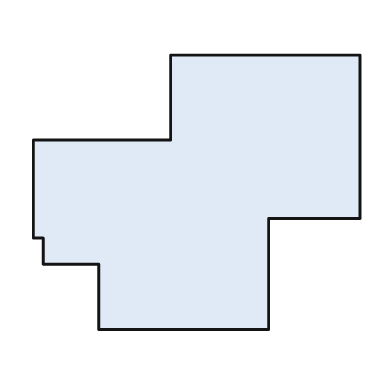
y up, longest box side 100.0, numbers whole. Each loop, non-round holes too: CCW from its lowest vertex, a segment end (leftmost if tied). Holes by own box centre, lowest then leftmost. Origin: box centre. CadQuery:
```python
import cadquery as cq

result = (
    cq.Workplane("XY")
    .moveTo(-30.0, -42.0)
    .lineTo(22.0, -42.0)
    .lineTo(22.0, -8.0)
    .lineTo(50.0, -8.0)
    .lineTo(50.0, 42.0)
    .lineTo(-8.0, 42.0)
    .lineTo(-8.0, 16.0)
    .lineTo(-50.0, 16.0)
    .lineTo(-50.0, -14.0)
    .lineTo(-47.0, -14.0)
    .lineTo(-47.0, -22.0)
    .lineTo(-30.0, -22.0)
    .close()
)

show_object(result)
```